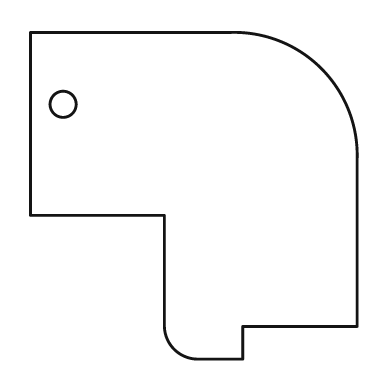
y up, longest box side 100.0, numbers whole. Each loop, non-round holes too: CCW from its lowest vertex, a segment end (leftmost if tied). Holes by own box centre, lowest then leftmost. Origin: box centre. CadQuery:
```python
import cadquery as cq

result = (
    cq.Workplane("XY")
    .moveTo(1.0, -50.0)
    .lineTo(15.0, -50.0)
    .lineTo(15.0, -40.0)
    .lineTo(50.0, -40.0)
    .lineTo(50.0, 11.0)
    .threePointArc((39.0, 39.0), (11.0, 50.0))
    .lineTo(-50.0, 50.0)
    .lineTo(-50.0, -6.0)
    .lineTo(-9.0, -6.0)
    .lineTo(-9.0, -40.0)
    .threePointArc((-6.0, -47.0), (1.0, -50.0))
    .close()
    .moveTo(-40.0, 28.0)
    .circle(4.0)
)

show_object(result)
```